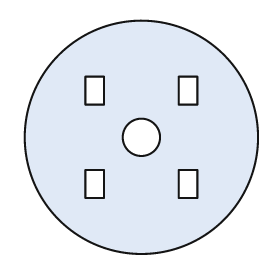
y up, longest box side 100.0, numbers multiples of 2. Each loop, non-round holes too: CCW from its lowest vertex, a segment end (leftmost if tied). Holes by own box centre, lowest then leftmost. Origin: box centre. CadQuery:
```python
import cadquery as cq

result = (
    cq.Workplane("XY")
    .moveTo(0.0, 0.0)
    .circle(50.0)
    .moveTo(-24.0, -26.0)
    .lineTo(-16.0, -26.0)
    .lineTo(-16.0, -14.0)
    .lineTo(-24.0, -14.0)
    .close()
    .moveTo(16.0, -26.0)
    .lineTo(24.0, -26.0)
    .lineTo(24.0, -14.0)
    .lineTo(16.0, -14.0)
    .close()
    .moveTo(0.0, 0.0)
    .circle(8.0)
    .moveTo(-24.0, 14.0)
    .lineTo(-16.0, 14.0)
    .lineTo(-16.0, 26.0)
    .lineTo(-24.0, 26.0)
    .close()
    .moveTo(16.0, 14.0)
    .lineTo(24.0, 14.0)
    .lineTo(24.0, 26.0)
    .lineTo(16.0, 26.0)
    .close()
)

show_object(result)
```